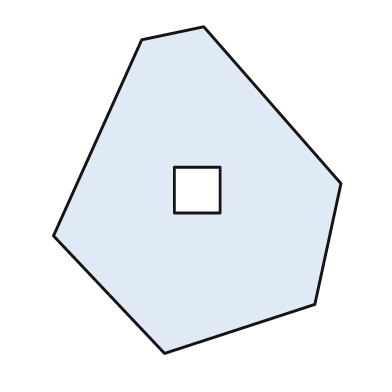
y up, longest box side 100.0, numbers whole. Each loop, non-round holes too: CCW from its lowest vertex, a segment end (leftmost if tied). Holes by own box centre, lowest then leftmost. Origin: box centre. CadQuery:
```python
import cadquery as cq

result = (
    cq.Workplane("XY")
    .moveTo(-10.0, -50.0)
    .lineTo(36.0, -35.0)
    .lineTo(44.0, 2.0)
    .lineTo(2.0, 50.0)
    .lineTo(-17.0, 46.0)
    .lineTo(-44.0, -14.0)
    .close()
    .moveTo(-7.0, -7.0)
    .lineTo(7.0, -7.0)
    .lineTo(7.0, 7.0)
    .lineTo(-7.0, 7.0)
    .close()
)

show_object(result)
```